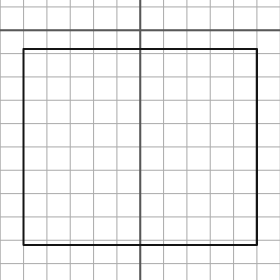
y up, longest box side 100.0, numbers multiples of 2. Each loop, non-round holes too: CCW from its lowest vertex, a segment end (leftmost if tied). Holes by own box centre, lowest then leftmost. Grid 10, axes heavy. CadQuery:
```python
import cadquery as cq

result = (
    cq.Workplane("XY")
    .moveTo(-50.0, -92.0)
    .lineTo(50.0, -92.0)
    .lineTo(50.0, -8.0)
    .lineTo(-50.0, -8.0)
    .close()
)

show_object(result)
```